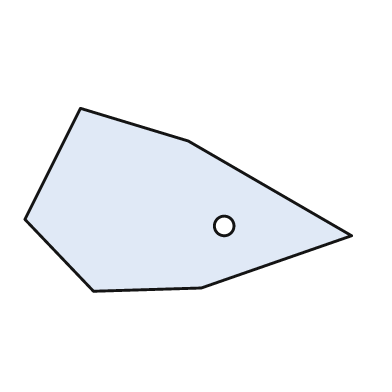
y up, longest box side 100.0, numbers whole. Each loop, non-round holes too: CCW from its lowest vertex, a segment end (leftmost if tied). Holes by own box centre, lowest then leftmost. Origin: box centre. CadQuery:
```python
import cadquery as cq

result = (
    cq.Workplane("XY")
    .moveTo(-29.0, -28.0)
    .lineTo(4.0, -27.0)
    .lineTo(50.0, -11.0)
    .lineTo(0.0, 18.0)
    .lineTo(-33.0, 28.0)
    .lineTo(-50.0, -6.0)
    .close()
    .moveTo(11.0, -8.0)
    .circle(3.0)
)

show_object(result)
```